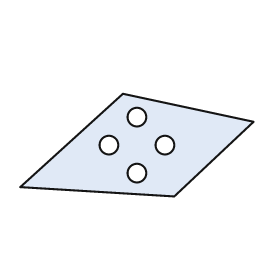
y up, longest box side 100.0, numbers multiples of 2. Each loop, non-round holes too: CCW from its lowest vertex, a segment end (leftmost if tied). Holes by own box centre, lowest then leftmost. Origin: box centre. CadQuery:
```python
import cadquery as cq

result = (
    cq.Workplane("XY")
    .moveTo(16.0, -22.0)
    .lineTo(50.0, 10.0)
    .lineTo(-6.0, 22.0)
    .lineTo(-50.0, -18.0)
    .close()
    .moveTo(0.0, -12.0)
    .circle(4.0)
    .moveTo(-12.0, 0.0)
    .circle(4.0)
    .moveTo(12.0, 0.0)
    .circle(4.0)
    .moveTo(0.0, 12.0)
    .circle(4.0)
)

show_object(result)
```